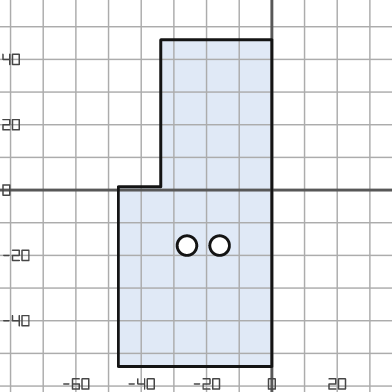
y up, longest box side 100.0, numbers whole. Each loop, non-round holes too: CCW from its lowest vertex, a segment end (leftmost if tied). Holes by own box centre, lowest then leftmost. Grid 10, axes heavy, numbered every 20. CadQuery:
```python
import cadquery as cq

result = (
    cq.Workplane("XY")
    .moveTo(-47.0, -54.0)
    .lineTo(0.0, -54.0)
    .lineTo(0.0, 46.0)
    .lineTo(-34.0, 46.0)
    .lineTo(-34.0, 1.0)
    .lineTo(-47.0, 1.0)
    .close()
    .moveTo(-26.0, -17.0)
    .circle(3.0)
    .moveTo(-16.0, -17.0)
    .circle(3.0)
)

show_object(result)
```